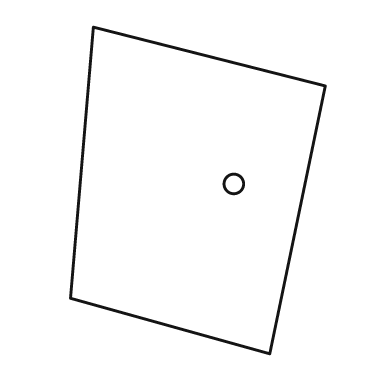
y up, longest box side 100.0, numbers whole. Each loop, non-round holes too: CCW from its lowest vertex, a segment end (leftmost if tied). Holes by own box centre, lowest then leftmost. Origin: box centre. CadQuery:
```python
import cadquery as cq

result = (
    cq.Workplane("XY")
    .moveTo(22.0, -50.0)
    .lineTo(39.0, 32.0)
    .lineTo(-32.0, 50.0)
    .lineTo(-39.0, -33.0)
    .close()
    .moveTo(11.0, 2.0)
    .circle(3.0)
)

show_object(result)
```